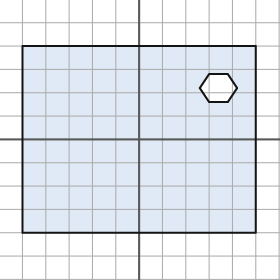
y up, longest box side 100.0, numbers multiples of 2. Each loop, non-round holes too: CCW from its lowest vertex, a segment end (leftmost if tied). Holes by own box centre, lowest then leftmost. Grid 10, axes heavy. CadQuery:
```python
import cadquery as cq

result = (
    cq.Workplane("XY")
    .moveTo(-50.0, -40.0)
    .lineTo(50.0, -40.0)
    .lineTo(50.0, 40.0)
    .lineTo(-50.0, 40.0)
    .close()
    .moveTo(30.0, 16.0)
    .lineTo(38.0, 16.0)
    .lineTo(42.0, 22.0)
    .lineTo(38.0, 28.0)
    .lineTo(30.0, 28.0)
    .lineTo(26.0, 22.0)
    .close()
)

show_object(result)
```